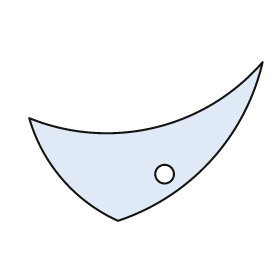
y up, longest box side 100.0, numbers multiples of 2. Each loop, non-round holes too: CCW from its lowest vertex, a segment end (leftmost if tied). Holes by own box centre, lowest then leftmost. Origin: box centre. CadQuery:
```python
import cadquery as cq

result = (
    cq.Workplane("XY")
    .moveTo(-12.0, -34.0)
    .threePointArc((28.0, -8.0), (50.0, 34.0))
    .threePointArc((4.0, 6.0), (-50.0, 10.0))
    .threePointArc((-36.0, -16.0), (-12.0, -34.0))
    .close()
    .moveTo(8.0, -14.0)
    .circle(4.0)
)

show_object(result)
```